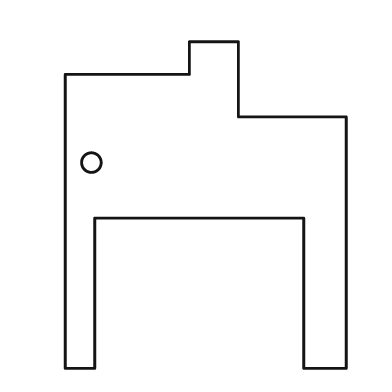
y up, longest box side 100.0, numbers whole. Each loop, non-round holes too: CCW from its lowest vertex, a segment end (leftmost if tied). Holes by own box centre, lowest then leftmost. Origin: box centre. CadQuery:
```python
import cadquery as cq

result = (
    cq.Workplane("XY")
    .moveTo(-43.0, -50.0)
    .lineTo(-34.0, -50.0)
    .lineTo(-34.0, -4.0)
    .lineTo(30.0, -4.0)
    .lineTo(30.0, -50.0)
    .lineTo(43.0, -50.0)
    .lineTo(43.0, 27.0)
    .lineTo(10.0, 27.0)
    .lineTo(10.0, 50.0)
    .lineTo(-5.0, 50.0)
    .lineTo(-5.0, 40.0)
    .lineTo(-43.0, 40.0)
    .close()
    .moveTo(-35.0, 13.0)
    .circle(3.0)
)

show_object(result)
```